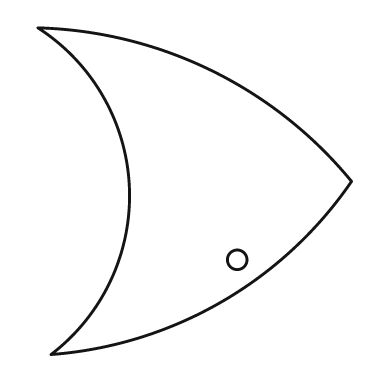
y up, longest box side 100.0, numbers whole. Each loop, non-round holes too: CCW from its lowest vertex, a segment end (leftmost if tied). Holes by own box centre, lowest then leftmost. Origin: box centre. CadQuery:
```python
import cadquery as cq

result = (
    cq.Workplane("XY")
    .moveTo(-44.0, -50.0)
    .threePointArc((8.0, -34.0), (48.0, 3.0))
    .threePointArc((5.0, 37.0), (-48.0, 50.0))
    .threePointArc((-20.0, 1.0), (-44.0, -50.0))
    .close()
    .moveTo(13.0, -21.0)
    .circle(3.0)
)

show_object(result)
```